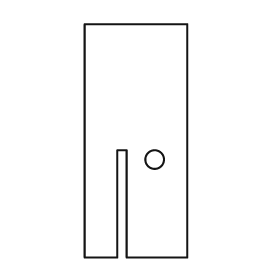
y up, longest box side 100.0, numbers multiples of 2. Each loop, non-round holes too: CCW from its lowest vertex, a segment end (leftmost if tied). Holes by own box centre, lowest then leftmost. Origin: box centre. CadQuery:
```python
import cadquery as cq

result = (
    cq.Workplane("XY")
    .moveTo(-22.0, -50.0)
    .lineTo(-8.0, -50.0)
    .lineTo(-8.0, -4.0)
    .lineTo(-4.0, -4.0)
    .lineTo(-4.0, -50.0)
    .lineTo(22.0, -50.0)
    .lineTo(22.0, 50.0)
    .lineTo(-22.0, 50.0)
    .close()
    .moveTo(8.0, -8.0)
    .circle(4.0)
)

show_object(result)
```